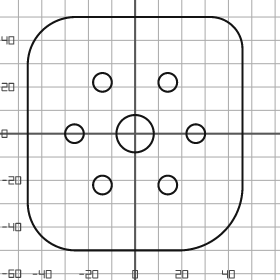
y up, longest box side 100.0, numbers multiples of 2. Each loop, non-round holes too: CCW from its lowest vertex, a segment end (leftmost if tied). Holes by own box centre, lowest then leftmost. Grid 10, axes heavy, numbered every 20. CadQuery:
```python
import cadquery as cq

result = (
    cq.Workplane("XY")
    .moveTo(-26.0, -50.0)
    .lineTo(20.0, -50.0)
    .threePointArc((38.0, -42.0), (46.0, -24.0))
    .lineTo(46.0, 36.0)
    .threePointArc((42.0, 46.0), (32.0, 50.0))
    .lineTo(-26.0, 50.0)
    .threePointArc((-40.0, 44.0), (-46.0, 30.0))
    .lineTo(-46.0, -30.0)
    .threePointArc((-40.0, -44.0), (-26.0, -50.0))
    .close()
    .moveTo(-14.0, -22.0)
    .circle(4.0)
    .moveTo(14.0, -22.0)
    .circle(4.0)
    .moveTo(-26.0, 0.0)
    .circle(4.0)
    .moveTo(0.0, 0.0)
    .circle(8.0)
    .moveTo(26.0, 0.0)
    .circle(4.0)
    .moveTo(-14.0, 22.0)
    .circle(4.0)
    .moveTo(14.0, 22.0)
    .circle(4.0)
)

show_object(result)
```